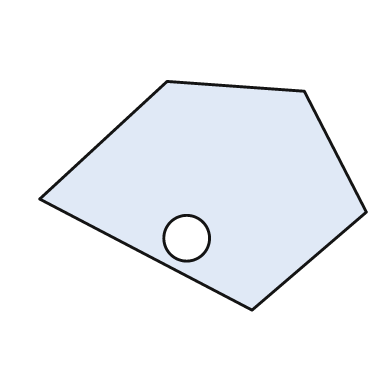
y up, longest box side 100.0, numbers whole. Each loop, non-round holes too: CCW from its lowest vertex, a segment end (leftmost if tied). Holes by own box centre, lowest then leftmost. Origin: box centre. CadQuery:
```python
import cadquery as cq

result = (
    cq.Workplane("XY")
    .moveTo(15.0, -35.0)
    .lineTo(50.0, -5.0)
    .lineTo(31.0, 32.0)
    .lineTo(-11.0, 35.0)
    .lineTo(-50.0, -1.0)
    .close()
    .moveTo(-5.0, -13.0)
    .circle(7.0)
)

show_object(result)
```